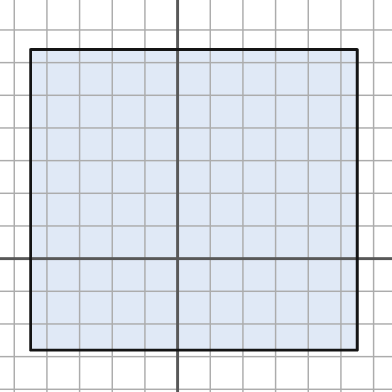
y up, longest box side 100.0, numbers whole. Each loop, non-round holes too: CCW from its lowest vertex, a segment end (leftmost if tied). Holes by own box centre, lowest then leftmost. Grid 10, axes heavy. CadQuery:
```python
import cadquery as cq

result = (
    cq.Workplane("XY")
    .moveTo(-45.0, -28.0)
    .lineTo(55.0, -28.0)
    .lineTo(55.0, 64.0)
    .lineTo(-45.0, 64.0)
    .close()
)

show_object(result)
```